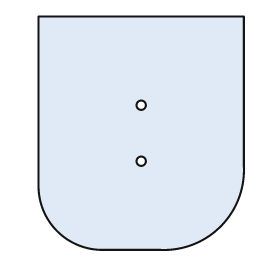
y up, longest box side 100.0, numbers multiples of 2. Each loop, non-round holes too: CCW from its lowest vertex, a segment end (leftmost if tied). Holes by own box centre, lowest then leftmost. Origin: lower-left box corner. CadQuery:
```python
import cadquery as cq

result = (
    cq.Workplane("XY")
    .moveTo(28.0, 0.0)
    .lineTo(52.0, 0.0)
    .threePointArc((78.0, 10.0), (88.0, 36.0))
    .lineTo(88.0, 100.0)
    .lineTo(0.0, 100.0)
    .lineTo(0.0, 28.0)
    .threePointArc((8.0, 8.0), (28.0, 0.0))
    .close()
    .moveTo(44.0, 38.0)
    .circle(2.0)
    .moveTo(44.0, 62.0)
    .circle(2.0)
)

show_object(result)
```